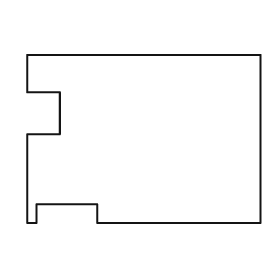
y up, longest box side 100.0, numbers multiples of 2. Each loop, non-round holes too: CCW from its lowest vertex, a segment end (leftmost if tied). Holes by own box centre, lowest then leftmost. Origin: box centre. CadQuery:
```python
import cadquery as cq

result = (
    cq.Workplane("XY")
    .moveTo(-50.0, -36.0)
    .lineTo(-46.0, -36.0)
    .lineTo(-46.0, -28.0)
    .lineTo(-20.0, -28.0)
    .lineTo(-20.0, -36.0)
    .lineTo(50.0, -36.0)
    .lineTo(50.0, 36.0)
    .lineTo(-50.0, 36.0)
    .lineTo(-50.0, 20.0)
    .lineTo(-36.0, 20.0)
    .lineTo(-36.0, 2.0)
    .lineTo(-50.0, 2.0)
    .close()
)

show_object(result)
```